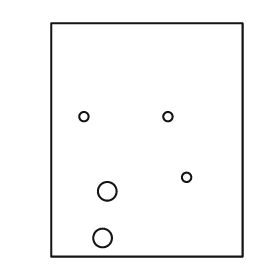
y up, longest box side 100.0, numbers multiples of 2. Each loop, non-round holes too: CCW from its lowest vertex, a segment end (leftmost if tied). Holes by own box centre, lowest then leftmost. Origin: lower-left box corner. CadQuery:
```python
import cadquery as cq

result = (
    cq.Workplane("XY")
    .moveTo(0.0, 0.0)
    .lineTo(82.0, 0.0)
    .lineTo(82.0, 100.0)
    .lineTo(0.0, 100.0)
    .close()
    .moveTo(22.0, 8.0)
    .circle(4.0)
    .moveTo(24.0, 28.0)
    .circle(4.0)
    .moveTo(58.0, 34.0)
    .circle(2.0)
    .moveTo(14.0, 60.0)
    .circle(2.0)
    .moveTo(50.0, 60.0)
    .circle(2.0)
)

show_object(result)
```